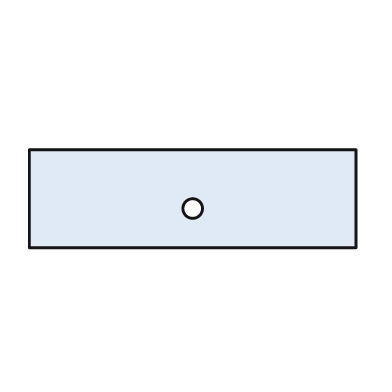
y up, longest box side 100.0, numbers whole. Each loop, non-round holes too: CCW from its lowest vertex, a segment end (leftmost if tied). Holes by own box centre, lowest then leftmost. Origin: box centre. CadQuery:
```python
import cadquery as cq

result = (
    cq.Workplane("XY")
    .moveTo(-50.0, -15.0)
    .lineTo(50.0, -15.0)
    .lineTo(50.0, 15.0)
    .lineTo(-50.0, 15.0)
    .close()
    .moveTo(0.0, -3.0)
    .circle(3.0)
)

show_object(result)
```